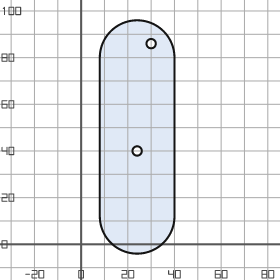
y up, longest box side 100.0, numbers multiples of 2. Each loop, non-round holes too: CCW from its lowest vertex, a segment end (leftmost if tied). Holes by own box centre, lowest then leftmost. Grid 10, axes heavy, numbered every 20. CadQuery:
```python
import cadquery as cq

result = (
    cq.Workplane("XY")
    .moveTo(8.0, 12.0)
    .threePointArc((24.0, -4.0), (40.0, 12.0))
    .lineTo(40.0, 80.0)
    .threePointArc((24.0, 96.0), (8.0, 80.0))
    .close()
    .moveTo(24.0, 40.0)
    .circle(2.0)
    .moveTo(30.0, 86.0)
    .circle(2.0)
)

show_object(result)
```